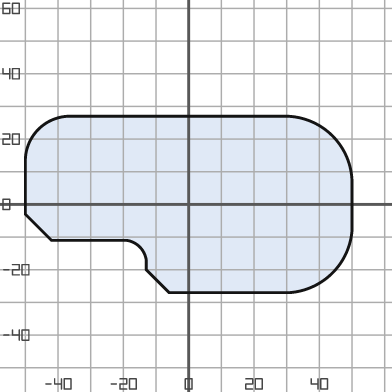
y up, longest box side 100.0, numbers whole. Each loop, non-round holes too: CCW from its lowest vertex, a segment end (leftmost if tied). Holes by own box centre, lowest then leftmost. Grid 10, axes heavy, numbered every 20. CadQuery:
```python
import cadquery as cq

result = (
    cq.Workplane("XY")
    .moveTo(-6.0, -27.0)
    .lineTo(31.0, -27.0)
    .threePointArc((44.0, -21.0), (50.0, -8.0))
    .lineTo(50.0, 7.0)
    .threePointArc((44.0, 21.0), (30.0, 27.0))
    .lineTo(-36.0, 27.0)
    .threePointArc((-46.0, 23.0), (-50.0, 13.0))
    .lineTo(-50.0, -3.0)
    .lineTo(-42.0, -11.0)
    .lineTo(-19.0, -11.0)
    .threePointArc((-15.0, -13.0), (-13.0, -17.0))
    .lineTo(-13.0, -20.0)
    .close()
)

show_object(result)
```